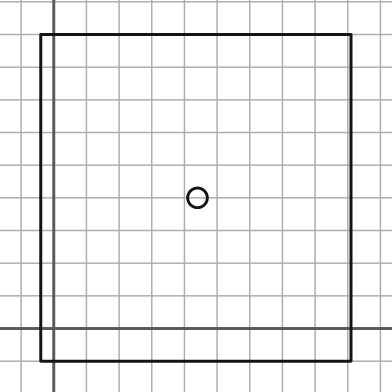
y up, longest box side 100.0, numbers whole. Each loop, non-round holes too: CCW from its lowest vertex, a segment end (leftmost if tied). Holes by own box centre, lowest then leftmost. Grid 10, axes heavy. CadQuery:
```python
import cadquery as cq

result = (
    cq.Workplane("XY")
    .moveTo(-4.0, -10.0)
    .lineTo(91.0, -10.0)
    .lineTo(91.0, 90.0)
    .lineTo(-4.0, 90.0)
    .close()
    .moveTo(44.0, 40.0)
    .circle(3.0)
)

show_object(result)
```